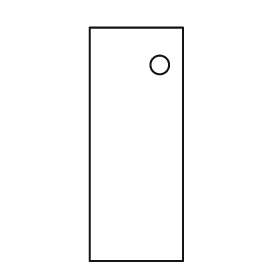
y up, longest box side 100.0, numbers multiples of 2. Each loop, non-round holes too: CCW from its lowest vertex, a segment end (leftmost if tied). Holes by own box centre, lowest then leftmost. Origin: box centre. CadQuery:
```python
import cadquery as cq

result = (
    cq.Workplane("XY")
    .moveTo(-20.0, -50.0)
    .lineTo(20.0, -50.0)
    .lineTo(20.0, 50.0)
    .lineTo(-20.0, 50.0)
    .close()
    .moveTo(10.0, 34.0)
    .circle(4.0)
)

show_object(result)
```